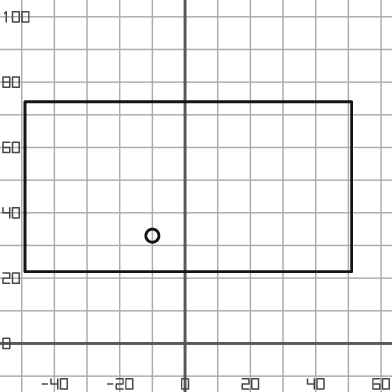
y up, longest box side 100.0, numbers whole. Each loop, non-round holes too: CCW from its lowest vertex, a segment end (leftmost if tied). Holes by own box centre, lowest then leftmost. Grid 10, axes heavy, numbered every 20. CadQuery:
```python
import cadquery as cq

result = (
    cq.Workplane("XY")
    .moveTo(-49.0, 22.0)
    .lineTo(51.0, 22.0)
    .lineTo(51.0, 74.0)
    .lineTo(-49.0, 74.0)
    .close()
    .moveTo(-10.0, 33.0)
    .circle(2.0)
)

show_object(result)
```